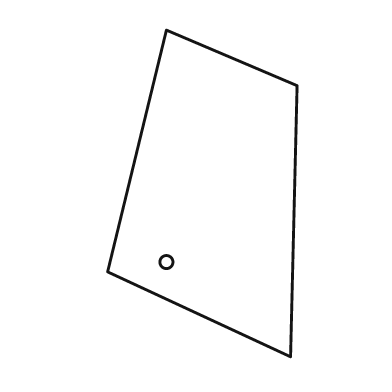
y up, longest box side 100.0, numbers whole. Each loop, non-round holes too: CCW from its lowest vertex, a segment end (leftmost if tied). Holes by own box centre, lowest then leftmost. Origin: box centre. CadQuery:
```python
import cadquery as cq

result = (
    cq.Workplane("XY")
    .moveTo(27.0, -50.0)
    .lineTo(29.0, 33.0)
    .lineTo(-11.0, 50.0)
    .lineTo(-29.0, -24.0)
    .close()
    .moveTo(-11.0, -21.0)
    .circle(2.0)
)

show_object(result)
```